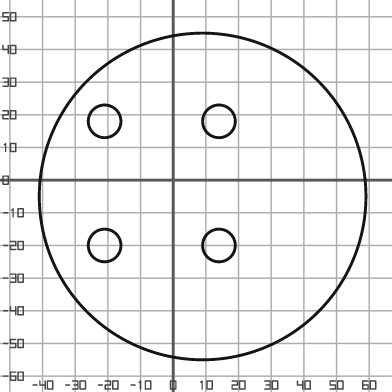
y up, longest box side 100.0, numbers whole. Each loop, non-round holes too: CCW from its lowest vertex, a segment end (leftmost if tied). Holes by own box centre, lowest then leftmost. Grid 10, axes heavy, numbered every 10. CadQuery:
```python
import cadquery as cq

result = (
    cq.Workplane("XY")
    .moveTo(9.0, -5.0)
    .circle(50.0)
    .moveTo(-21.0, -20.0)
    .circle(5.0)
    .moveTo(14.0, -20.0)
    .circle(5.0)
    .moveTo(-21.0, 18.0)
    .circle(5.0)
    .moveTo(14.0, 18.0)
    .circle(5.0)
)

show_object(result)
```